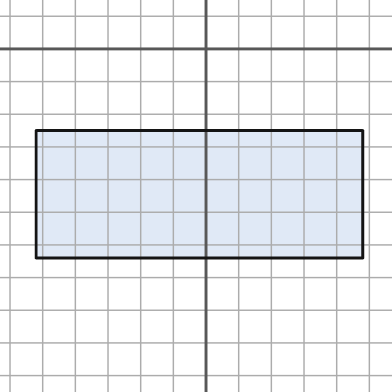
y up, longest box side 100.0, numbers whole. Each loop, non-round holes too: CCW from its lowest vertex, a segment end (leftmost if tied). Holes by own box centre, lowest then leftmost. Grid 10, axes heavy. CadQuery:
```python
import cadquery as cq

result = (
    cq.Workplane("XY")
    .moveTo(-52.0, -64.0)
    .lineTo(48.0, -64.0)
    .lineTo(48.0, -25.0)
    .lineTo(-52.0, -25.0)
    .close()
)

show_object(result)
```